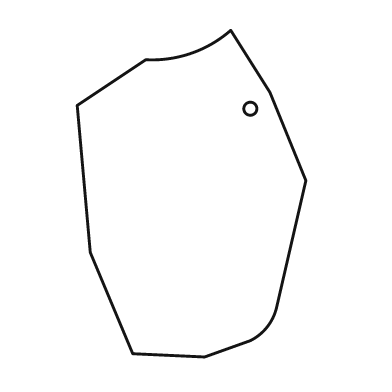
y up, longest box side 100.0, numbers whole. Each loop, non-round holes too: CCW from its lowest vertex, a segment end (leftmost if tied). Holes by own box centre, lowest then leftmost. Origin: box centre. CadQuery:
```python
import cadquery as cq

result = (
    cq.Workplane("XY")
    .moveTo(4.0, -50.0)
    .lineTo(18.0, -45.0)
    .threePointArc((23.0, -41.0), (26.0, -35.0))
    .lineTo(35.0, 4.0)
    .lineTo(24.0, 31.0)
    .lineTo(12.0, 50.0)
    .threePointArc((0.0, 43.0), (-14.0, 41.0))
    .lineTo(-35.0, 27.0)
    .lineTo(-31.0, -18.0)
    .lineTo(-18.0, -49.0)
    .close()
    .moveTo(18.0, 26.0)
    .circle(2.0)
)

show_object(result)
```